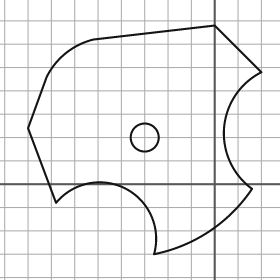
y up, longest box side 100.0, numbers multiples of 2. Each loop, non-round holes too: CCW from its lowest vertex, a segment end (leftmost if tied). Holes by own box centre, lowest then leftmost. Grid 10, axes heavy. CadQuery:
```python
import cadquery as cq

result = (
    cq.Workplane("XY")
    .moveTo(-26.0, -30.0)
    .threePointArc((-2.0, -20.0), (16.0, -2.0))
    .threePointArc((4.0, 24.0), (20.0, 48.0))
    .lineTo(0.0, 68.0)
    .lineTo(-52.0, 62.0)
    .threePointArc((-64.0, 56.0), (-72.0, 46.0))
    .lineTo(-80.0, 24.0)
    .lineTo(-68.0, -8.0)
    .threePointArc((-38.0, -2.0), (-26.0, -30.0))
    .close()
    .moveTo(-30.0, 20.0)
    .circle(6.0)
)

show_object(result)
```